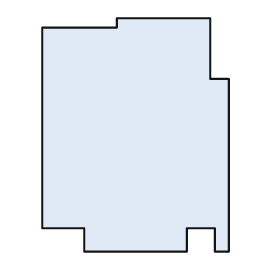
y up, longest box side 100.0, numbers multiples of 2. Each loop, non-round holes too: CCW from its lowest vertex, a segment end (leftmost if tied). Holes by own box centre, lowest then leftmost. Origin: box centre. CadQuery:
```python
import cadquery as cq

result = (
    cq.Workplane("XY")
    .moveTo(-22.0, -50.0)
    .lineTo(22.0, -50.0)
    .lineTo(22.0, -40.0)
    .lineTo(34.0, -40.0)
    .lineTo(34.0, -50.0)
    .lineTo(40.0, -50.0)
    .lineTo(40.0, 24.0)
    .lineTo(32.0, 24.0)
    .lineTo(32.0, 50.0)
    .lineTo(-8.0, 50.0)
    .lineTo(-8.0, 46.0)
    .lineTo(-40.0, 46.0)
    .lineTo(-40.0, -40.0)
    .lineTo(-22.0, -40.0)
    .close()
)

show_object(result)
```